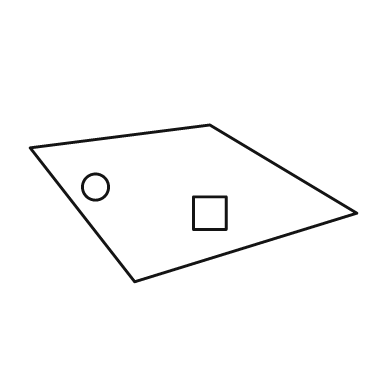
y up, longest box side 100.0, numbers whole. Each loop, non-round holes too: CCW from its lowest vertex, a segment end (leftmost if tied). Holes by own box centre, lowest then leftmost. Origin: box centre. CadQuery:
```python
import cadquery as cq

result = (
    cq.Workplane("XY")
    .moveTo(-18.0, -24.0)
    .lineTo(50.0, -3.0)
    .lineTo(5.0, 24.0)
    .lineTo(-50.0, 17.0)
    .close()
    .moveTo(0.0, -8.0)
    .lineTo(10.0, -8.0)
    .lineTo(10.0, 2.0)
    .lineTo(0.0, 2.0)
    .close()
    .moveTo(-30.0, 5.0)
    .circle(4.0)
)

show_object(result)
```